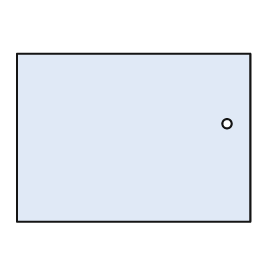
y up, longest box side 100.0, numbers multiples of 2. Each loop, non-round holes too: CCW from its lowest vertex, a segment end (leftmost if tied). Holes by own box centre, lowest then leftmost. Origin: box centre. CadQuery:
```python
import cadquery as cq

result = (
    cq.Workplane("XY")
    .moveTo(-50.0, -36.0)
    .lineTo(50.0, -36.0)
    .lineTo(50.0, 36.0)
    .lineTo(-50.0, 36.0)
    .close()
    .moveTo(40.0, 6.0)
    .circle(2.0)
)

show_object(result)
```